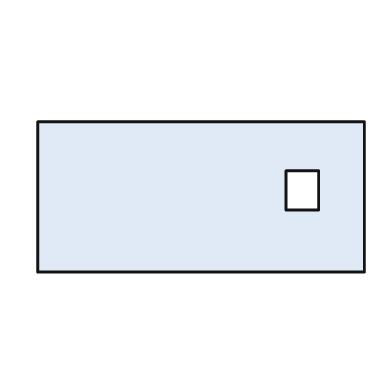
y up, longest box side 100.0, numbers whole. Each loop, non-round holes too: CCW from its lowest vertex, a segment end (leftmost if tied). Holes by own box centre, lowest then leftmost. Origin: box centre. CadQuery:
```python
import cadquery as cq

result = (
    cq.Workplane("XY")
    .moveTo(-50.0, -23.0)
    .lineTo(50.0, -23.0)
    .lineTo(50.0, 23.0)
    .lineTo(-50.0, 23.0)
    .close()
    .moveTo(26.0, -4.0)
    .lineTo(36.0, -4.0)
    .lineTo(36.0, 8.0)
    .lineTo(26.0, 8.0)
    .close()
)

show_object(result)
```